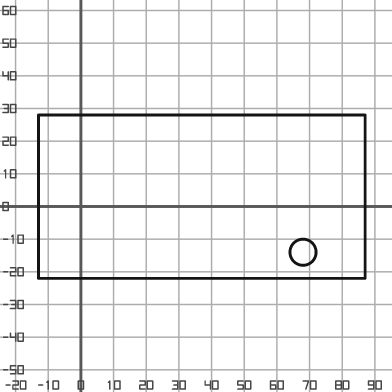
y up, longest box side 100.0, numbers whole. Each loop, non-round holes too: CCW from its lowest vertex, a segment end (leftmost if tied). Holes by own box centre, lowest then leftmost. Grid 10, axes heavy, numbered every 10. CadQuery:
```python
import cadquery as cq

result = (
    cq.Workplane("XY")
    .moveTo(-13.0, -22.0)
    .lineTo(87.0, -22.0)
    .lineTo(87.0, 28.0)
    .lineTo(-13.0, 28.0)
    .close()
    .moveTo(68.0, -14.0)
    .circle(4.0)
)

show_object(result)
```